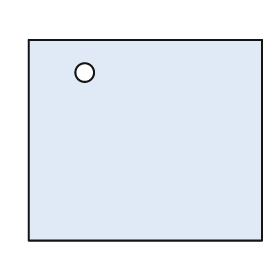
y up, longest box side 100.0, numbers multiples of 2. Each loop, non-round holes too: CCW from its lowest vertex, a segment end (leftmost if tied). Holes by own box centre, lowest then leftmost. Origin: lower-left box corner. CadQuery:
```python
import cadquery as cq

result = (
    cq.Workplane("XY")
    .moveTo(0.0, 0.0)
    .lineTo(100.0, 0.0)
    .lineTo(100.0, 86.0)
    .lineTo(0.0, 86.0)
    .close()
    .moveTo(24.0, 72.0)
    .circle(4.0)
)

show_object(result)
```